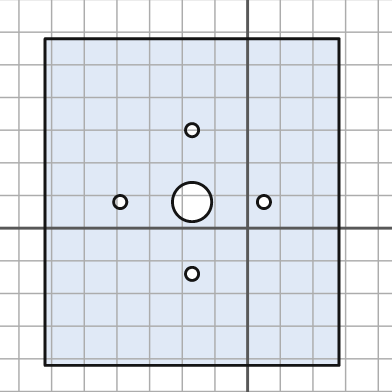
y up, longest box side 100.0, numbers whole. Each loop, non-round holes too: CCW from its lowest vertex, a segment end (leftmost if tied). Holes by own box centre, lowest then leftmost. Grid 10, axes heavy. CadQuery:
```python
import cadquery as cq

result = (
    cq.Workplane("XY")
    .moveTo(-62.0, -42.0)
    .lineTo(28.0, -42.0)
    .lineTo(28.0, 58.0)
    .lineTo(-62.0, 58.0)
    .close()
    .moveTo(-17.0, -14.0)
    .circle(2.0)
    .moveTo(-39.0, 8.0)
    .circle(2.0)
    .moveTo(-17.0, 8.0)
    .circle(6.0)
    .moveTo(5.0, 8.0)
    .circle(2.0)
    .moveTo(-17.0, 30.0)
    .circle(2.0)
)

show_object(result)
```